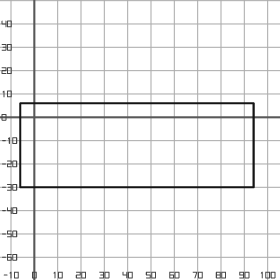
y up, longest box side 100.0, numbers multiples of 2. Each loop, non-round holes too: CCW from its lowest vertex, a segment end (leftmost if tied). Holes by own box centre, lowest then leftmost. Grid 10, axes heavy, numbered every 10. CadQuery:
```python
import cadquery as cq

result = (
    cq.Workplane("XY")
    .moveTo(-6.0, -30.0)
    .lineTo(94.0, -30.0)
    .lineTo(94.0, 6.0)
    .lineTo(-6.0, 6.0)
    .close()
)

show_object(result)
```